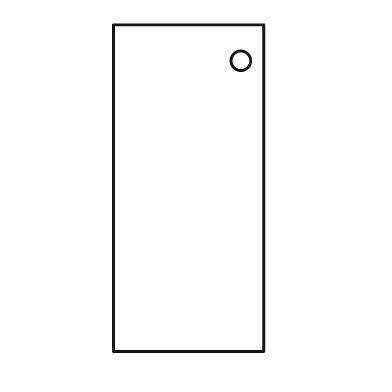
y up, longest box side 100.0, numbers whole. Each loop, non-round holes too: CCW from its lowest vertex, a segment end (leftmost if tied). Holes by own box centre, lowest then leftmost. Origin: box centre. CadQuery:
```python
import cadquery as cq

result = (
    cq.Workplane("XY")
    .moveTo(-23.0, -50.0)
    .lineTo(23.0, -50.0)
    .lineTo(23.0, 50.0)
    .lineTo(-23.0, 50.0)
    .close()
    .moveTo(16.0, 39.0)
    .circle(3.0)
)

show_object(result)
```